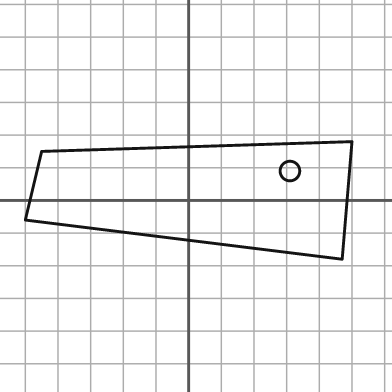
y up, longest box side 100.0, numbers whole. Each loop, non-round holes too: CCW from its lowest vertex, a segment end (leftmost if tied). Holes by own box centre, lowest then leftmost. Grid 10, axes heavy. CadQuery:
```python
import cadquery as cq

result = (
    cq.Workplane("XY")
    .moveTo(47.0, -18.0)
    .lineTo(50.0, 18.0)
    .lineTo(-45.0, 15.0)
    .lineTo(-50.0, -6.0)
    .close()
    .moveTo(31.0, 9.0)
    .circle(3.0)
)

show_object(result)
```